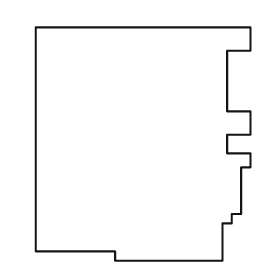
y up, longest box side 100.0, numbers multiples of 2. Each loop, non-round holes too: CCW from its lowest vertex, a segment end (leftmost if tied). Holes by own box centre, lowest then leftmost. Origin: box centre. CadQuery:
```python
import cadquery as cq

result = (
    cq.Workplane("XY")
    .moveTo(-12.0, -50.0)
    .lineTo(34.0, -50.0)
    .lineTo(34.0, -34.0)
    .lineTo(38.0, -34.0)
    .lineTo(38.0, -30.0)
    .lineTo(42.0, -30.0)
    .lineTo(42.0, -10.0)
    .lineTo(46.0, -10.0)
    .lineTo(46.0, -4.0)
    .lineTo(36.0, -4.0)
    .lineTo(36.0, 4.0)
    .lineTo(46.0, 4.0)
    .lineTo(46.0, 14.0)
    .lineTo(36.0, 14.0)
    .lineTo(36.0, 40.0)
    .lineTo(46.0, 40.0)
    .lineTo(46.0, 50.0)
    .lineTo(-46.0, 50.0)
    .lineTo(-46.0, -46.0)
    .lineTo(-12.0, -46.0)
    .close()
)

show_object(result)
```